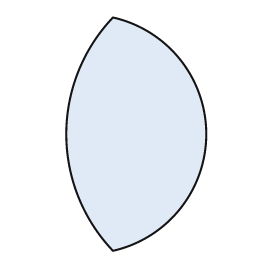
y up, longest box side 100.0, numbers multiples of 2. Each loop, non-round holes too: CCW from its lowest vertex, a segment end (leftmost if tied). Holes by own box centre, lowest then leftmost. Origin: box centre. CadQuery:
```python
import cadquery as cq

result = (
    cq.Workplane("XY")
    .moveTo(-10.0, -50.0)
    .threePointArc((30.0, 0.0), (-10.0, 50.0))
    .threePointArc((-30.0, 0.0), (-10.0, -50.0))
    .close()
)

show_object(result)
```